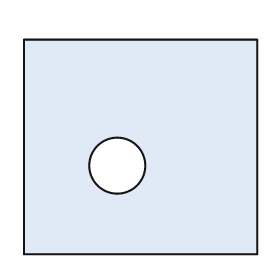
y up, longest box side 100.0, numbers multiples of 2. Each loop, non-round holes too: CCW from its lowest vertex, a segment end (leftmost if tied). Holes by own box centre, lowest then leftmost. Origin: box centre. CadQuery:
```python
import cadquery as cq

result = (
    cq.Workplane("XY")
    .moveTo(-50.0, -46.0)
    .lineTo(50.0, -46.0)
    .lineTo(50.0, 46.0)
    .lineTo(-50.0, 46.0)
    .close()
    .moveTo(-10.0, -8.0)
    .circle(12.0)
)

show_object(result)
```